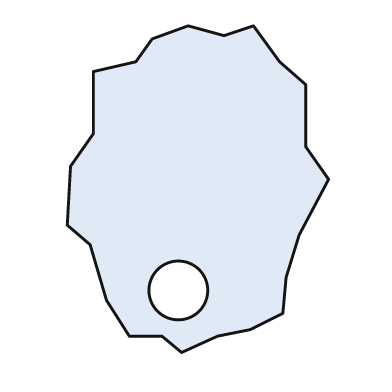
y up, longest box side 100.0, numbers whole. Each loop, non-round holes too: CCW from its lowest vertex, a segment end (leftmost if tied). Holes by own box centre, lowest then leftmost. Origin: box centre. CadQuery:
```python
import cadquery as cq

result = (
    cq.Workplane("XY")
    .moveTo(-5.0, -50.0)
    .lineTo(6.0, -45.0)
    .lineTo(16.0, -43.0)
    .lineTo(26.0, -38.0)
    .lineTo(27.0, -27.0)
    .lineTo(31.0, -14.0)
    .lineTo(40.0, 3.0)
    .lineTo(33.0, 13.0)
    .lineTo(33.0, 32.0)
    .lineTo(25.0, 39.0)
    .lineTo(17.0, 50.0)
    .lineTo(8.0, 47.0)
    .lineTo(-3.0, 50.0)
    .lineTo(-14.0, 46.0)
    .lineTo(-19.0, 39.0)
    .lineTo(-32.0, 36.0)
    .lineTo(-32.0, 17.0)
    .lineTo(-39.0, 7.0)
    .lineTo(-40.0, -11.0)
    .lineTo(-33.0, -17.0)
    .lineTo(-28.0, -34.0)
    .lineTo(-21.0, -45.0)
    .lineTo(-11.0, -45.0)
    .close()
    .moveTo(-6.0, -31.0)
    .circle(9.0)
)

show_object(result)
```